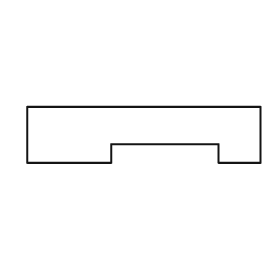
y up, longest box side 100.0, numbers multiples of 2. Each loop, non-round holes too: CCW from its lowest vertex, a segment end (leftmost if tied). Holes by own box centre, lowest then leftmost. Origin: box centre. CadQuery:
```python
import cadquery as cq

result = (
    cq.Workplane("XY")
    .moveTo(-50.0, -12.0)
    .lineTo(-14.0, -12.0)
    .lineTo(-14.0, -4.0)
    .lineTo(32.0, -4.0)
    .lineTo(32.0, -12.0)
    .lineTo(50.0, -12.0)
    .lineTo(50.0, 12.0)
    .lineTo(-50.0, 12.0)
    .close()
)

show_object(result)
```